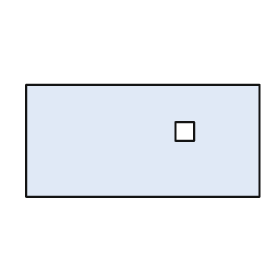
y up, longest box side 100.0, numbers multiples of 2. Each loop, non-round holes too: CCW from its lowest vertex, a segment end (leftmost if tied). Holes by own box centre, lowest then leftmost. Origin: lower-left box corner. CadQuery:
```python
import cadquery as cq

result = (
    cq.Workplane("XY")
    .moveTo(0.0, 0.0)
    .lineTo(100.0, 0.0)
    .lineTo(100.0, 48.0)
    .lineTo(0.0, 48.0)
    .close()
    .moveTo(64.0, 24.0)
    .lineTo(72.0, 24.0)
    .lineTo(72.0, 32.0)
    .lineTo(64.0, 32.0)
    .close()
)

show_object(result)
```